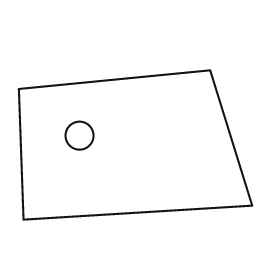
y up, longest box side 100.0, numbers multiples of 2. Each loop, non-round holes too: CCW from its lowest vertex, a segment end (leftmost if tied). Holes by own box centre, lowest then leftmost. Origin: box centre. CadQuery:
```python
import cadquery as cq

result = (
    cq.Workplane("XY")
    .moveTo(-48.0, -32.0)
    .lineTo(50.0, -26.0)
    .lineTo(32.0, 32.0)
    .lineTo(-50.0, 24.0)
    .close()
    .moveTo(-24.0, 4.0)
    .circle(6.0)
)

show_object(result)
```